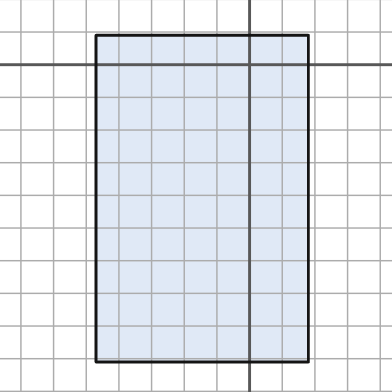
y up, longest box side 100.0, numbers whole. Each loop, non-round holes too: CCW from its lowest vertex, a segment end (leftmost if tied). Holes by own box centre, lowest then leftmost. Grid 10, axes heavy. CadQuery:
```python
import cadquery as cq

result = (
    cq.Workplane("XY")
    .moveTo(-47.0, -91.0)
    .lineTo(18.0, -91.0)
    .lineTo(18.0, 9.0)
    .lineTo(-47.0, 9.0)
    .close()
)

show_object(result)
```